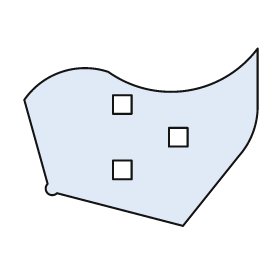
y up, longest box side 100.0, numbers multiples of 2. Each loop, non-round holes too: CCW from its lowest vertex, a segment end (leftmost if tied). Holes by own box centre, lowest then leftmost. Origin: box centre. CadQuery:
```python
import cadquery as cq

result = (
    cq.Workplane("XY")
    .moveTo(18.0, -38.0)
    .lineTo(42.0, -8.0)
    .threePointArc((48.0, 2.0), (50.0, 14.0))
    .lineTo(50.0, 38.0)
    .threePointArc((20.0, 20.0), (-14.0, 28.0))
    .threePointArc((-34.0, 28.0), (-50.0, 16.0))
    .lineTo(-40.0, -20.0)
    .threePointArc((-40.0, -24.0), (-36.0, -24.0))
    .close()
    .moveTo(-12.0, -18.0)
    .lineTo(-4.0, -18.0)
    .lineTo(-4.0, -10.0)
    .lineTo(-12.0, -10.0)
    .close()
    .moveTo(12.0, -4.0)
    .lineTo(20.0, -4.0)
    .lineTo(20.0, 4.0)
    .lineTo(12.0, 4.0)
    .close()
    .moveTo(-12.0, 10.0)
    .lineTo(-4.0, 10.0)
    .lineTo(-4.0, 18.0)
    .lineTo(-12.0, 18.0)
    .close()
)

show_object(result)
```